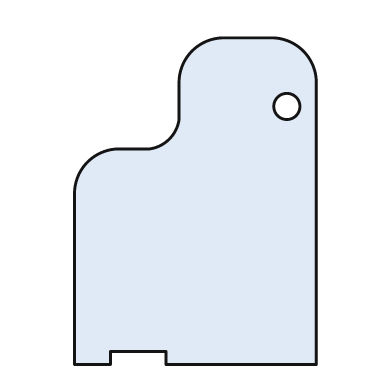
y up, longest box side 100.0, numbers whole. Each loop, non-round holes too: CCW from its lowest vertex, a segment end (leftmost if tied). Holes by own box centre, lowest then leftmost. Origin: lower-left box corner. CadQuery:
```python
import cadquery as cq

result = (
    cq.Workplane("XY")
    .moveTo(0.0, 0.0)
    .lineTo(11.0, 0.0)
    .lineTo(11.0, 4.0)
    .lineTo(28.0, 4.0)
    .lineTo(28.0, 0.0)
    .lineTo(74.0, 0.0)
    .lineTo(74.0, 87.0)
    .threePointArc((70.0, 96.0), (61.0, 100.0))
    .lineTo(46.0, 100.0)
    .threePointArc((36.0, 96.0), (32.0, 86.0))
    .lineTo(32.0, 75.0)
    .threePointArc((29.0, 69.0), (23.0, 66.0))
    .lineTo(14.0, 66.0)
    .threePointArc((4.0, 62.0), (0.0, 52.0))
    .close()
    .moveTo(65.0, 79.0)
    .circle(4.0)
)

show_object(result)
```